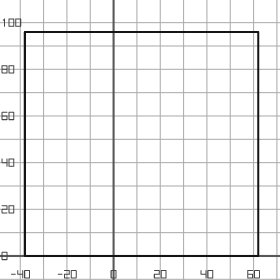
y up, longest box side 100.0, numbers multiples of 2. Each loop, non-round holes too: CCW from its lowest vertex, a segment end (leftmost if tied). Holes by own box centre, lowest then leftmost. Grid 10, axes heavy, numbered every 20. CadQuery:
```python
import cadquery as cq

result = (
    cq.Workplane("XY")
    .moveTo(-38.0, 0.0)
    .lineTo(62.0, 0.0)
    .lineTo(62.0, 96.0)
    .lineTo(-38.0, 96.0)
    .close()
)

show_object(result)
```